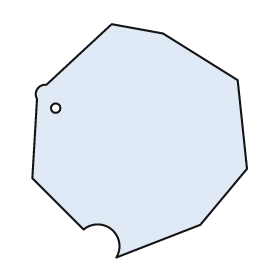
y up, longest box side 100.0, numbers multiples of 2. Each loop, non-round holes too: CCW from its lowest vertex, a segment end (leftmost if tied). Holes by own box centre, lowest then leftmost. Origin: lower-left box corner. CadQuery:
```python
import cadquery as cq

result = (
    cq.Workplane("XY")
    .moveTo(36.0, 0.0)
    .lineTo(72.0, 14.0)
    .lineTo(92.0, 38.0)
    .lineTo(88.0, 76.0)
    .lineTo(56.0, 96.0)
    .lineTo(34.0, 100.0)
    .lineTo(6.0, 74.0)
    .threePointArc((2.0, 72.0), (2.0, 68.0))
    .lineTo(0.0, 34.0)
    .lineTo(22.0, 12.0)
    .threePointArc((34.0, 12.0), (36.0, 0.0))
    .close()
    .moveTo(10.0, 64.0)
    .circle(2.0)
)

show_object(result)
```